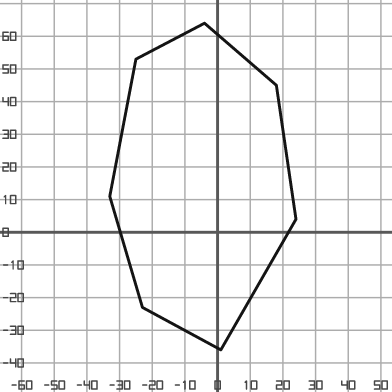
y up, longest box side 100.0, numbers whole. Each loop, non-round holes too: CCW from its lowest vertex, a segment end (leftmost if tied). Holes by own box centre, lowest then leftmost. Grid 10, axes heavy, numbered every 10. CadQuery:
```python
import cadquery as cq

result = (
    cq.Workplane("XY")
    .moveTo(1.0, -36.0)
    .lineTo(24.0, 4.0)
    .lineTo(18.0, 45.0)
    .lineTo(-4.0, 64.0)
    .lineTo(-25.0, 53.0)
    .lineTo(-33.0, 11.0)
    .lineTo(-23.0, -23.0)
    .close()
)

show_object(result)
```